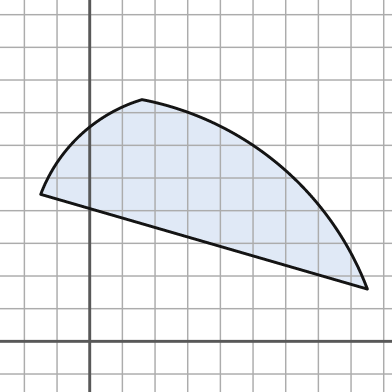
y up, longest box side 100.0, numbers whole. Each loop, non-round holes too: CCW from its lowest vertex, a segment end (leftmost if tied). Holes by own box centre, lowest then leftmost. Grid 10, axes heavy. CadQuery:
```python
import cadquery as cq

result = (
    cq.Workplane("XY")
    .moveTo(85.0, 16.0)
    .threePointArc((58.0, 54.0), (16.0, 74.0))
    .threePointArc((-3.0, 63.0), (-15.0, 45.0))
    .close()
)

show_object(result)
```